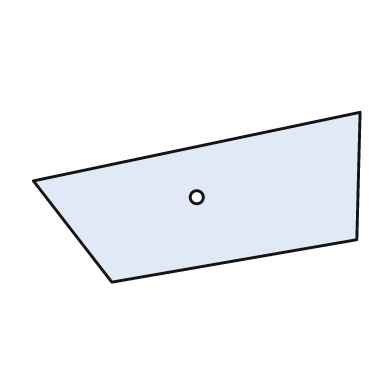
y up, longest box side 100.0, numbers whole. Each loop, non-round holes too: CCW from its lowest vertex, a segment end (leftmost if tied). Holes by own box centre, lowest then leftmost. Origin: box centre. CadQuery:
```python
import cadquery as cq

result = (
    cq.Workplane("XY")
    .moveTo(-26.0, -26.0)
    .lineTo(49.0, -13.0)
    .lineTo(50.0, 26.0)
    .lineTo(-50.0, 5.0)
    .close()
    .moveTo(0.0, 0.0)
    .circle(2.0)
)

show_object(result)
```